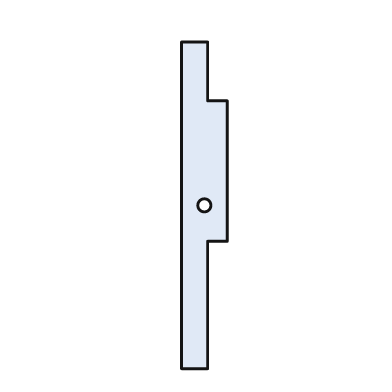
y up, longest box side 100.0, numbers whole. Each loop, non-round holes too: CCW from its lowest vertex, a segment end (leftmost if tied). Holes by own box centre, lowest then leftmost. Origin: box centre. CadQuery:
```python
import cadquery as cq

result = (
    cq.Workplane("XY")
    .moveTo(-7.0, -50.0)
    .lineTo(1.0, -50.0)
    .lineTo(1.0, -11.0)
    .lineTo(7.0, -11.0)
    .lineTo(7.0, 32.0)
    .lineTo(1.0, 32.0)
    .lineTo(1.0, 50.0)
    .lineTo(-7.0, 50.0)
    .close()
    .moveTo(0.0, 0.0)
    .circle(2.0)
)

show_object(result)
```